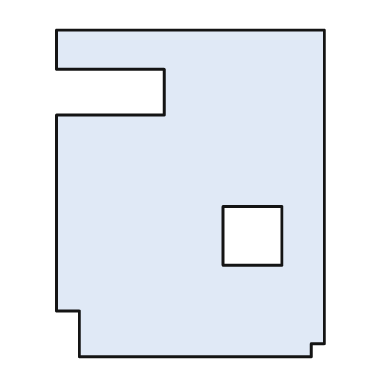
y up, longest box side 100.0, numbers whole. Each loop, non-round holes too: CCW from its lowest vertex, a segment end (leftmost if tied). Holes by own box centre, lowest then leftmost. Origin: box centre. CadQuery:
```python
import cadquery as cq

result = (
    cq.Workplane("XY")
    .moveTo(-34.0, -50.0)
    .lineTo(37.0, -50.0)
    .lineTo(37.0, -46.0)
    .lineTo(41.0, -46.0)
    .lineTo(41.0, 50.0)
    .lineTo(-41.0, 50.0)
    .lineTo(-41.0, 38.0)
    .lineTo(-8.0, 38.0)
    .lineTo(-8.0, 24.0)
    .lineTo(-41.0, 24.0)
    .lineTo(-41.0, -36.0)
    .lineTo(-34.0, -36.0)
    .close()
    .moveTo(10.0, -22.0)
    .lineTo(28.0, -22.0)
    .lineTo(28.0, -4.0)
    .lineTo(10.0, -4.0)
    .close()
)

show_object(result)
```